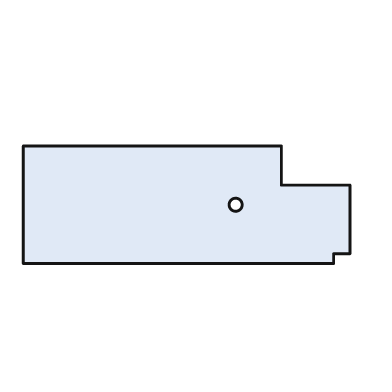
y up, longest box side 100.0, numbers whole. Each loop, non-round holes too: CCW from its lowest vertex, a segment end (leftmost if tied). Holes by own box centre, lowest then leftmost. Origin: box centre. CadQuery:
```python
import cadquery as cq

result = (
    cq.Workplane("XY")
    .moveTo(-50.0, -18.0)
    .lineTo(45.0, -18.0)
    .lineTo(45.0, -15.0)
    .lineTo(50.0, -15.0)
    .lineTo(50.0, 6.0)
    .lineTo(29.0, 6.0)
    .lineTo(29.0, 18.0)
    .lineTo(-50.0, 18.0)
    .close()
    .moveTo(15.0, 0.0)
    .circle(2.0)
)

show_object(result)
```